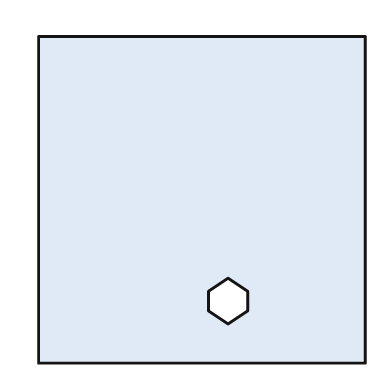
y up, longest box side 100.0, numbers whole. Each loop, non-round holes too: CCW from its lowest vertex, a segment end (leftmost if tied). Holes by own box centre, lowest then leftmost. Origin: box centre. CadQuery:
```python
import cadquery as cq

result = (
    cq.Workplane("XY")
    .moveTo(-50.0, -50.0)
    .lineTo(50.0, -50.0)
    .lineTo(50.0, 50.0)
    .lineTo(-50.0, 50.0)
    .close()
    .moveTo(8.0, -38.0)
    .lineTo(14.0, -34.0)
    .lineTo(14.0, -28.0)
    .lineTo(8.0, -24.0)
    .lineTo(2.0, -28.0)
    .lineTo(2.0, -34.0)
    .close()
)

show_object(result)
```